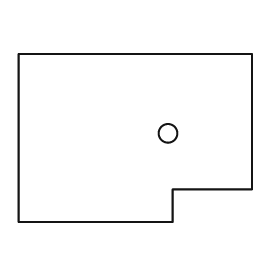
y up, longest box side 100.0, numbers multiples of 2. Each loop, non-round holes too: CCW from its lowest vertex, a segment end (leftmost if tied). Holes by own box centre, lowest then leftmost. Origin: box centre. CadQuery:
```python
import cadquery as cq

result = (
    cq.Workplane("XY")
    .moveTo(-50.0, -36.0)
    .lineTo(16.0, -36.0)
    .lineTo(16.0, -22.0)
    .lineTo(50.0, -22.0)
    .lineTo(50.0, 36.0)
    .lineTo(-50.0, 36.0)
    .close()
    .moveTo(14.0, 2.0)
    .circle(4.0)
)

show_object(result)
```